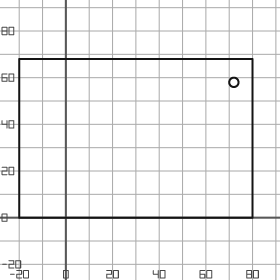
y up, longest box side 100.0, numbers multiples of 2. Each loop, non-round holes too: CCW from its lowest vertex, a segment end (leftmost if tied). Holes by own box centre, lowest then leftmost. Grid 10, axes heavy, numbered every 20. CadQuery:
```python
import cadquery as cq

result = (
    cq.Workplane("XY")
    .moveTo(-20.0, 0.0)
    .lineTo(80.0, 0.0)
    .lineTo(80.0, 68.0)
    .lineTo(-20.0, 68.0)
    .close()
    .moveTo(72.0, 58.0)
    .circle(2.0)
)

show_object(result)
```